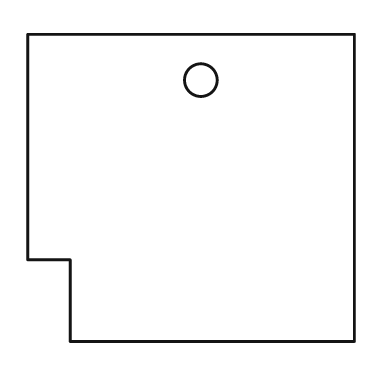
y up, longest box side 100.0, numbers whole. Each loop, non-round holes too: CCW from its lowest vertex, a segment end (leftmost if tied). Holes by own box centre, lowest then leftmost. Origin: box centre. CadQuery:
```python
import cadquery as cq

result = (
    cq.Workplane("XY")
    .moveTo(-37.0, -47.0)
    .lineTo(50.0, -47.0)
    .lineTo(50.0, 47.0)
    .lineTo(-50.0, 47.0)
    .lineTo(-50.0, -22.0)
    .lineTo(-37.0, -22.0)
    .close()
    .moveTo(3.0, 33.0)
    .circle(5.0)
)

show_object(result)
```